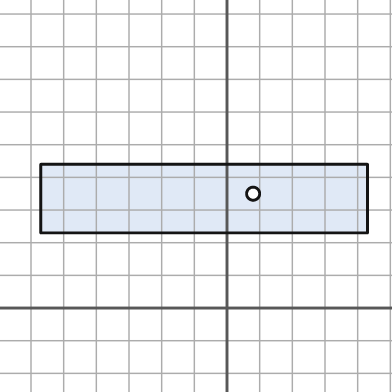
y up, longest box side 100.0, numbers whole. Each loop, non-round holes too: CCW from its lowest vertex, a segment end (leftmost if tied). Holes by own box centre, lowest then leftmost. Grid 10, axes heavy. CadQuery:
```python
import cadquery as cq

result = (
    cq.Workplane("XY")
    .moveTo(-57.0, 23.0)
    .lineTo(43.0, 23.0)
    .lineTo(43.0, 44.0)
    .lineTo(-57.0, 44.0)
    .close()
    .moveTo(8.0, 35.0)
    .circle(2.0)
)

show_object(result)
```